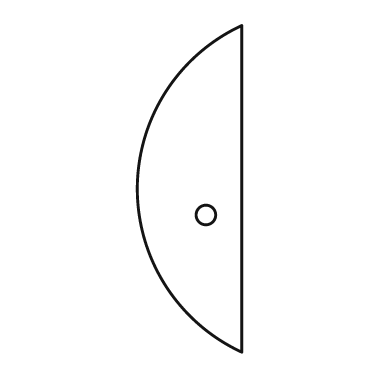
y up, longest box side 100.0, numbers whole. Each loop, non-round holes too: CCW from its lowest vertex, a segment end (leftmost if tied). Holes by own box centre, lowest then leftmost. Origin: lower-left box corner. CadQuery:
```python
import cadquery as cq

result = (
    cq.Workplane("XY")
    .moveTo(32.0, 0.0)
    .lineTo(32.0, 100.0)
    .threePointArc((0.0, 50.0), (32.0, 0.0))
    .close()
    .moveTo(21.0, 42.0)
    .circle(3.0)
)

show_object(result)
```